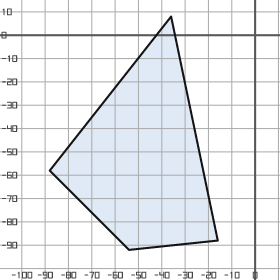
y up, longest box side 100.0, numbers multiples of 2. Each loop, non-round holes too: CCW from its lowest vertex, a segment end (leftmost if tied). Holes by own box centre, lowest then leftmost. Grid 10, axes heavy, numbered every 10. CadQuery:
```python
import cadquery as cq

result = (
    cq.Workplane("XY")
    .moveTo(-54.0, -92.0)
    .lineTo(-16.0, -88.0)
    .lineTo(-36.0, 8.0)
    .lineTo(-88.0, -58.0)
    .close()
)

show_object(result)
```